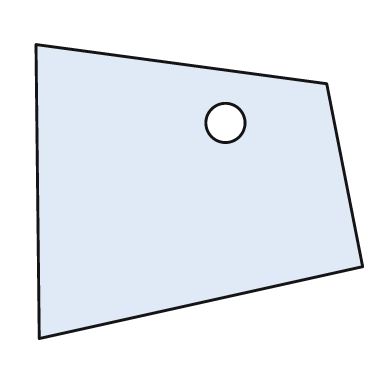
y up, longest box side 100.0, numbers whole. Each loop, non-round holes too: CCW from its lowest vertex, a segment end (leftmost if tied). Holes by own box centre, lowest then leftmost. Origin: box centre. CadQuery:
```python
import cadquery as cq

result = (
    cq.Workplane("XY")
    .moveTo(-49.0, -45.0)
    .lineTo(50.0, -23.0)
    .lineTo(39.0, 33.0)
    .lineTo(-50.0, 45.0)
    .close()
    .moveTo(8.0, 21.0)
    .circle(6.0)
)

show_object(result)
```